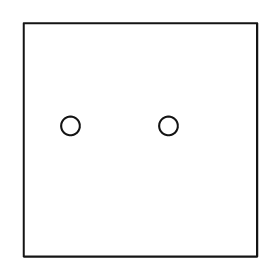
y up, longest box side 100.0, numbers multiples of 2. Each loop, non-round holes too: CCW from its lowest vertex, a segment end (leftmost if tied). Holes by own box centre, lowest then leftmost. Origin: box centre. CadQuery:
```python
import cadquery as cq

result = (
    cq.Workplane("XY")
    .moveTo(-50.0, -50.0)
    .lineTo(50.0, -50.0)
    .lineTo(50.0, 50.0)
    .lineTo(-50.0, 50.0)
    .close()
    .moveTo(-30.0, 6.0)
    .circle(4.0)
    .moveTo(12.0, 6.0)
    .circle(4.0)
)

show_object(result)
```